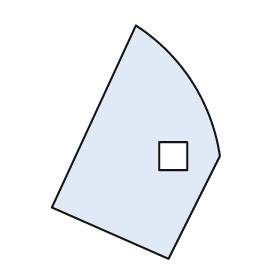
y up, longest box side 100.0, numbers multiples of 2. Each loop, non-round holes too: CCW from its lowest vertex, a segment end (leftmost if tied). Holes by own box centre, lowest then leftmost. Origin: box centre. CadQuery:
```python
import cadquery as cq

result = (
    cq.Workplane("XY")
    .moveTo(14.0, -50.0)
    .lineTo(36.0, -6.0)
    .threePointArc((24.0, 26.0), (0.0, 50.0))
    .lineTo(-36.0, -28.0)
    .close()
    .moveTo(10.0, -12.0)
    .lineTo(22.0, -12.0)
    .lineTo(22.0, 0.0)
    .lineTo(10.0, 0.0)
    .close()
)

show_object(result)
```